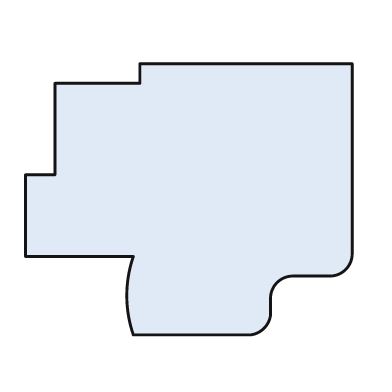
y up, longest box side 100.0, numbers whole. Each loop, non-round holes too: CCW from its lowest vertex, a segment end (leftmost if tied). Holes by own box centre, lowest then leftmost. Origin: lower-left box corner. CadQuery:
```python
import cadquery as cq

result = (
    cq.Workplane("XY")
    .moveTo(33.0, 0.0)
    .lineTo(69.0, 0.0)
    .threePointArc((73.0, 2.0), (75.0, 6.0))
    .lineTo(75.0, 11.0)
    .threePointArc((77.0, 16.0), (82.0, 18.0))
    .lineTo(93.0, 18.0)
    .threePointArc((98.0, 20.0), (100.0, 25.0))
    .lineTo(100.0, 83.0)
    .lineTo(35.0, 83.0)
    .lineTo(35.0, 77.0)
    .lineTo(9.0, 77.0)
    .lineTo(9.0, 49.0)
    .lineTo(0.0, 49.0)
    .lineTo(0.0, 24.0)
    .lineTo(33.0, 24.0)
    .threePointArc((31.0, 12.0), (33.0, 0.0))
    .close()
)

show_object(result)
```